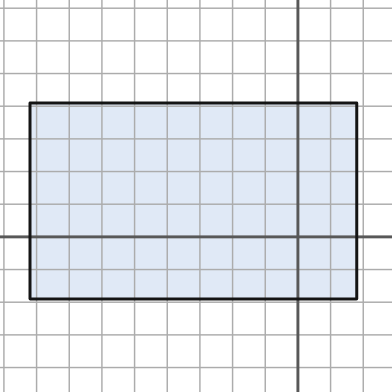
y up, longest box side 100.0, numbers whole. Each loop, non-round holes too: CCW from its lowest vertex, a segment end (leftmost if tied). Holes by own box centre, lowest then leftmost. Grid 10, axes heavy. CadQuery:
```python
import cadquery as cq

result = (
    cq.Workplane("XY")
    .moveTo(-82.0, -19.0)
    .lineTo(18.0, -19.0)
    .lineTo(18.0, 41.0)
    .lineTo(-82.0, 41.0)
    .close()
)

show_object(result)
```